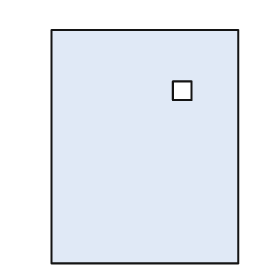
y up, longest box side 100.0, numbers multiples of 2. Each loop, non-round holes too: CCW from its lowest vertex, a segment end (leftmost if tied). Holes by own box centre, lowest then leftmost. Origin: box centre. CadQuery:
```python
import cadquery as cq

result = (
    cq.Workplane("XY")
    .moveTo(-40.0, -50.0)
    .lineTo(40.0, -50.0)
    .lineTo(40.0, 50.0)
    .lineTo(-40.0, 50.0)
    .close()
    .moveTo(12.0, 20.0)
    .lineTo(20.0, 20.0)
    .lineTo(20.0, 28.0)
    .lineTo(12.0, 28.0)
    .close()
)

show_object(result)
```